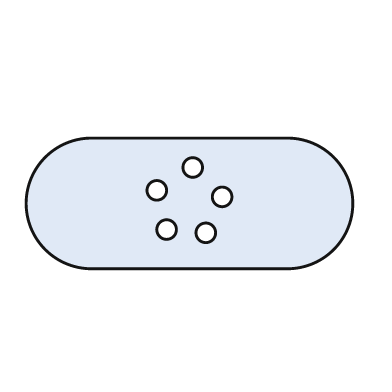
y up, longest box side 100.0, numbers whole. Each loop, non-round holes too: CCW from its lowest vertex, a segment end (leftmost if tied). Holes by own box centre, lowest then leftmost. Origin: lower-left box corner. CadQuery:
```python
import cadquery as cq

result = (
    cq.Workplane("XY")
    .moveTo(20.0, 0.0)
    .lineTo(80.0, 0.0)
    .threePointArc((100.0, 20.0), (80.0, 40.0))
    .lineTo(20.0, 40.0)
    .threePointArc((0.0, 20.0), (20.0, 0.0))
    .close()
    .moveTo(55.0, 11.0)
    .circle(3.0)
    .moveTo(43.0, 12.0)
    .circle(3.0)
    .moveTo(60.0, 22.0)
    .circle(3.0)
    .moveTo(40.0, 24.0)
    .circle(3.0)
    .moveTo(51.0, 31.0)
    .circle(3.0)
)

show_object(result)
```